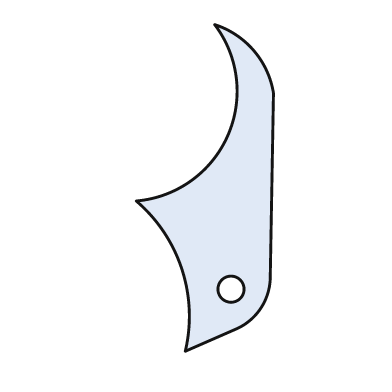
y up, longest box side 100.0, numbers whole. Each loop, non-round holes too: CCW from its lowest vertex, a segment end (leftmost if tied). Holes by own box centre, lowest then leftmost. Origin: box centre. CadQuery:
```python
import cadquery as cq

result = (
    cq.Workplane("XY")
    .moveTo(-6.0, -50.0)
    .lineTo(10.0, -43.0)
    .threePointArc((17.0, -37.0), (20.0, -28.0))
    .lineTo(21.0, 29.0)
    .threePointArc((15.0, 42.0), (3.0, 50.0))
    .threePointArc((7.0, 16.0), (-21.0, -4.0))
    .threePointArc((-7.0, -25.0), (-6.0, -50.0))
    .close()
    .moveTo(8.0, -31.0)
    .circle(4.0)
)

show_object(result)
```